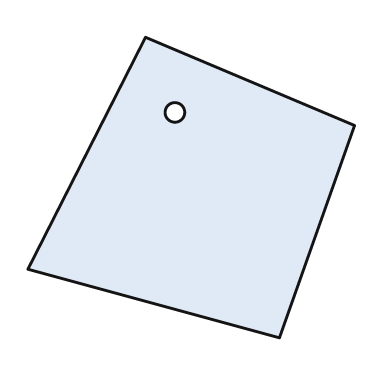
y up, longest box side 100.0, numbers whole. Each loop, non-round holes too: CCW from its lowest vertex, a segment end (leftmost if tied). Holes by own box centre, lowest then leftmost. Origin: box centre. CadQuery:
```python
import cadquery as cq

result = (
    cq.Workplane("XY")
    .moveTo(27.0, -46.0)
    .lineTo(50.0, 19.0)
    .lineTo(-14.0, 46.0)
    .lineTo(-50.0, -25.0)
    .close()
    .moveTo(-5.0, 23.0)
    .circle(3.0)
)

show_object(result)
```